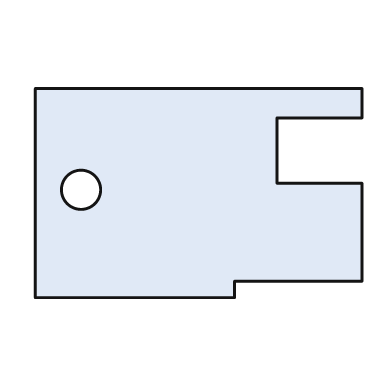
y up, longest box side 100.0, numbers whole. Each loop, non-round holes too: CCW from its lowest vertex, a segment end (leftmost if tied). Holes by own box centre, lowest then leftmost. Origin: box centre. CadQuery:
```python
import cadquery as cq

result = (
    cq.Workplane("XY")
    .moveTo(-50.0, -32.0)
    .lineTo(11.0, -32.0)
    .lineTo(11.0, -27.0)
    .lineTo(50.0, -27.0)
    .lineTo(50.0, 3.0)
    .lineTo(24.0, 3.0)
    .lineTo(24.0, 23.0)
    .lineTo(50.0, 23.0)
    .lineTo(50.0, 32.0)
    .lineTo(-50.0, 32.0)
    .close()
    .moveTo(-36.0, 1.0)
    .circle(6.0)
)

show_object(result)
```